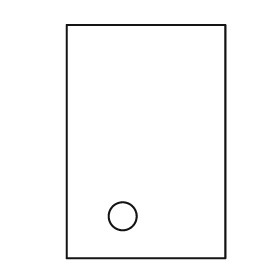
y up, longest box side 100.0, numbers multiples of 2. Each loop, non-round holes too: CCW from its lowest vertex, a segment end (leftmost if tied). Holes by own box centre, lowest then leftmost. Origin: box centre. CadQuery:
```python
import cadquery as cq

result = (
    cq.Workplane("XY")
    .moveTo(-34.0, -50.0)
    .lineTo(34.0, -50.0)
    .lineTo(34.0, 50.0)
    .lineTo(-34.0, 50.0)
    .close()
    .moveTo(-10.0, -32.0)
    .circle(6.0)
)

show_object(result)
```